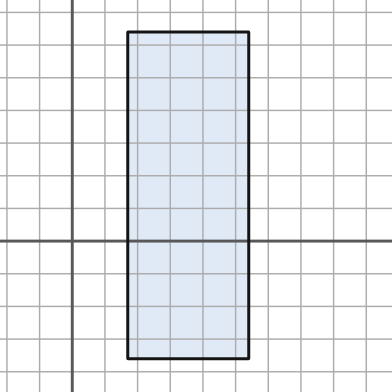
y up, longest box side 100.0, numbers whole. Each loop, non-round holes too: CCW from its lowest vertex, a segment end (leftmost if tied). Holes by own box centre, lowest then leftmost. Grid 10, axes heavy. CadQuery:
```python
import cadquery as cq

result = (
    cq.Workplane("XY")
    .moveTo(17.0, -36.0)
    .lineTo(54.0, -36.0)
    .lineTo(54.0, 64.0)
    .lineTo(17.0, 64.0)
    .close()
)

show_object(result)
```